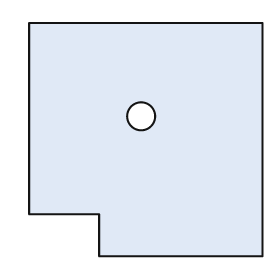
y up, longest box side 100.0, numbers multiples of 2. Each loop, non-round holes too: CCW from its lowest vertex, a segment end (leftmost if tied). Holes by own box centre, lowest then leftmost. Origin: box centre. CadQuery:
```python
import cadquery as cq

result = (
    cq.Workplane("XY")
    .moveTo(-20.0, -50.0)
    .lineTo(50.0, -50.0)
    .lineTo(50.0, 50.0)
    .lineTo(-50.0, 50.0)
    .lineTo(-50.0, -32.0)
    .lineTo(-20.0, -32.0)
    .close()
    .moveTo(-2.0, 10.0)
    .circle(6.0)
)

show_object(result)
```